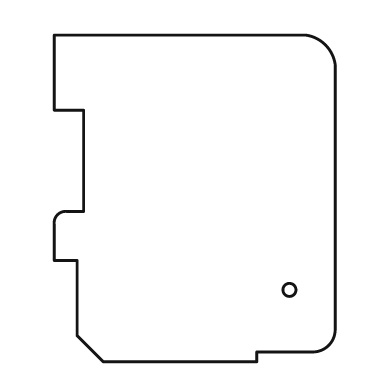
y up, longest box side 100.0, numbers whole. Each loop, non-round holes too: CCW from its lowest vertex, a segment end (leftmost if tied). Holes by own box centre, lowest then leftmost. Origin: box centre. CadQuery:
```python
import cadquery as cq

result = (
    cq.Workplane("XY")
    .moveTo(-28.0, -50.0)
    .lineTo(19.0, -50.0)
    .lineTo(19.0, -47.0)
    .lineTo(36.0, -47.0)
    .threePointArc((41.0, -45.0), (43.0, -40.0))
    .lineTo(43.0, 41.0)
    .threePointArc((40.0, 47.0), (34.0, 50.0))
    .lineTo(-43.0, 50.0)
    .lineTo(-43.0, 27.0)
    .lineTo(-34.0, 27.0)
    .lineTo(-34.0, -4.0)
    .lineTo(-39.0, -4.0)
    .threePointArc((-42.0, -5.0), (-43.0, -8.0))
    .lineTo(-43.0, -19.0)
    .lineTo(-36.0, -19.0)
    .lineTo(-36.0, -42.0)
    .close()
    .moveTo(29.0, -28.0)
    .circle(2.0)
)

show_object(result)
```